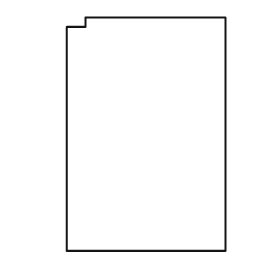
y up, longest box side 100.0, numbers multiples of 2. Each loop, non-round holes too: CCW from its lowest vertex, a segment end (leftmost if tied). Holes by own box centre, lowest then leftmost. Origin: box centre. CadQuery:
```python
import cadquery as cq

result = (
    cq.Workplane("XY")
    .moveTo(-34.0, -50.0)
    .lineTo(34.0, -50.0)
    .lineTo(34.0, 50.0)
    .lineTo(-26.0, 50.0)
    .lineTo(-26.0, 46.0)
    .lineTo(-34.0, 46.0)
    .close()
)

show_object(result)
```